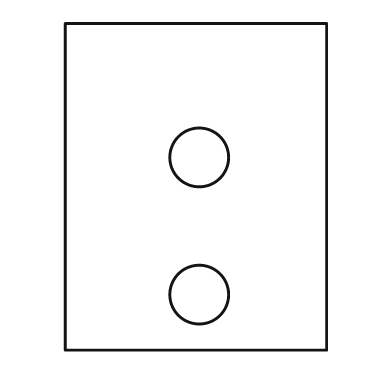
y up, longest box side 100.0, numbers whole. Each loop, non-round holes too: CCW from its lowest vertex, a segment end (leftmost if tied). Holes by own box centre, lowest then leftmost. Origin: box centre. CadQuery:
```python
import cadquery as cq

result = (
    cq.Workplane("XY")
    .moveTo(-40.0, -50.0)
    .lineTo(40.0, -50.0)
    .lineTo(40.0, 50.0)
    .lineTo(-40.0, 50.0)
    .close()
    .moveTo(1.0, -33.0)
    .circle(9.0)
    .moveTo(1.0, 9.0)
    .circle(9.0)
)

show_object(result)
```